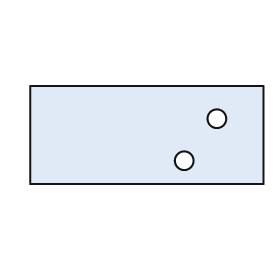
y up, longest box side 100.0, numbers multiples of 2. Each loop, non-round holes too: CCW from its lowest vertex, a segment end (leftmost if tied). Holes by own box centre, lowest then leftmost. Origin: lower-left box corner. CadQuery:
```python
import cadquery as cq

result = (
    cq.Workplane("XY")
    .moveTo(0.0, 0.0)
    .lineTo(100.0, 0.0)
    .lineTo(100.0, 42.0)
    .lineTo(0.0, 42.0)
    .close()
    .moveTo(66.0, 10.0)
    .circle(4.0)
    .moveTo(80.0, 28.0)
    .circle(4.0)
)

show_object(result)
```